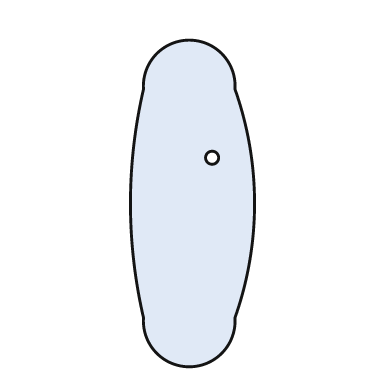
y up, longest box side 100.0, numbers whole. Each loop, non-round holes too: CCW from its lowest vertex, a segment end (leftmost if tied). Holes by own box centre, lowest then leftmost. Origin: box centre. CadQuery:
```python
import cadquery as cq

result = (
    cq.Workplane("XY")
    .moveTo(-15.0, -35.0)
    .threePointArc((-1.0, -50.0), (13.0, -35.0))
    .threePointArc((19.0, 0.0), (13.0, 35.0))
    .threePointArc((-1.0, 50.0), (-15.0, 35.0))
    .threePointArc((-19.0, 0.0), (-15.0, -35.0))
    .close()
    .moveTo(6.0, 14.0)
    .circle(2.0)
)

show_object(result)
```